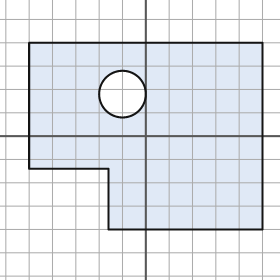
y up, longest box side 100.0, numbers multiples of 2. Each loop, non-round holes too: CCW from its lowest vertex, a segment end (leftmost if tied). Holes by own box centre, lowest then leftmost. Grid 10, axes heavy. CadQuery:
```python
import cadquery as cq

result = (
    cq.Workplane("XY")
    .moveTo(-16.0, -40.0)
    .lineTo(50.0, -40.0)
    .lineTo(50.0, 40.0)
    .lineTo(-50.0, 40.0)
    .lineTo(-50.0, -14.0)
    .lineTo(-16.0, -14.0)
    .close()
    .moveTo(-10.0, 18.0)
    .circle(10.0)
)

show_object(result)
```